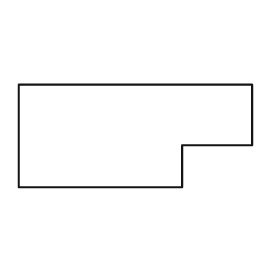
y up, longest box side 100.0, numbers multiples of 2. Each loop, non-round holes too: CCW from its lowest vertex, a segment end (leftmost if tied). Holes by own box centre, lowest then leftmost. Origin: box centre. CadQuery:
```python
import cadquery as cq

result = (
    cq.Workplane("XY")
    .moveTo(-50.0, -22.0)
    .lineTo(20.0, -22.0)
    .lineTo(20.0, -4.0)
    .lineTo(50.0, -4.0)
    .lineTo(50.0, 22.0)
    .lineTo(-50.0, 22.0)
    .close()
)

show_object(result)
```